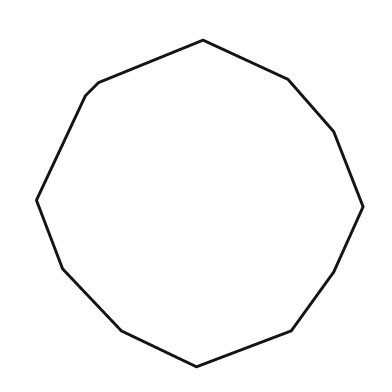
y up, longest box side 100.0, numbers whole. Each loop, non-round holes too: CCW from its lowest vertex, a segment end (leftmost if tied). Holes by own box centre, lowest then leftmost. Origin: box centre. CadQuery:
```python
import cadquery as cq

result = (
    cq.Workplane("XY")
    .moveTo(-1.0, -50.0)
    .lineTo(28.0, -39.0)
    .lineTo(41.0, -21.0)
    .lineTo(50.0, -1.0)
    .lineTo(41.0, 22.0)
    .lineTo(27.0, 38.0)
    .lineTo(1.0, 50.0)
    .lineTo(-31.0, 37.0)
    .lineTo(-35.0, 33.0)
    .lineTo(-50.0, 1.0)
    .lineTo(-42.0, -20.0)
    .lineTo(-24.0, -39.0)
    .close()
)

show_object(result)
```